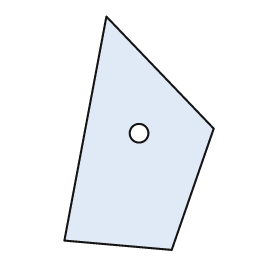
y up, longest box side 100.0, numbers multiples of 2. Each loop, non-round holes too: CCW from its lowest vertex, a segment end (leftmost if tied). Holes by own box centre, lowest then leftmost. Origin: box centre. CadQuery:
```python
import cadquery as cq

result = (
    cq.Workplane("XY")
    .moveTo(14.0, -50.0)
    .lineTo(32.0, 2.0)
    .lineTo(-14.0, 50.0)
    .lineTo(-32.0, -46.0)
    .close()
    .moveTo(0.0, 0.0)
    .circle(4.0)
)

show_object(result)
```